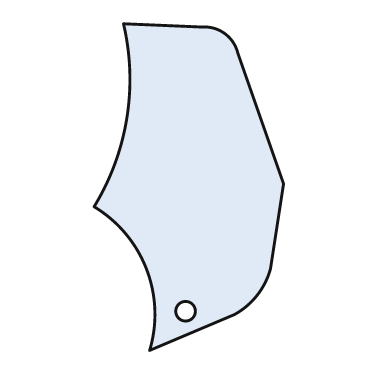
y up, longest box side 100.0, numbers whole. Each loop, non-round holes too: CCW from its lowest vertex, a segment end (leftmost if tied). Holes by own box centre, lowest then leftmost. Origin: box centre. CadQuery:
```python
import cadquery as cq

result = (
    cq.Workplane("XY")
    .moveTo(-12.0, -50.0)
    .lineTo(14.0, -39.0)
    .threePointArc((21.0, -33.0), (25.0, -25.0))
    .lineTo(29.0, 1.0)
    .lineTo(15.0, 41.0)
    .threePointArc((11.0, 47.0), (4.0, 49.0))
    .lineTo(-20.0, 50.0)
    .threePointArc((-19.0, 21.0), (-29.0, -6.0))
    .threePointArc((-13.0, -25.0), (-12.0, -50.0))
    .close()
    .moveTo(-1.0, -38.0)
    .circle(3.0)
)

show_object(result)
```